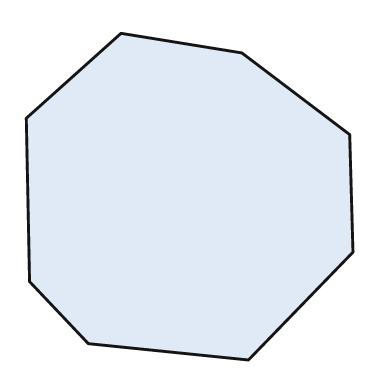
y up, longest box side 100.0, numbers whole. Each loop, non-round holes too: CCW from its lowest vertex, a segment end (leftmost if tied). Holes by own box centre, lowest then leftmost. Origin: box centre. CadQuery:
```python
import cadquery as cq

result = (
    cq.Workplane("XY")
    .moveTo(18.0, -50.0)
    .lineTo(50.0, -17.0)
    .lineTo(49.0, 19.0)
    .lineTo(16.0, 44.0)
    .lineTo(-21.0, 50.0)
    .lineTo(-50.0, 24.0)
    .lineTo(-49.0, -26.0)
    .lineTo(-31.0, -45.0)
    .close()
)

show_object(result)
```